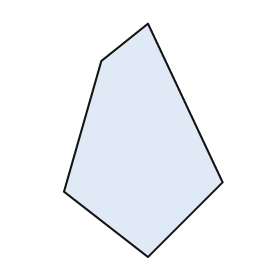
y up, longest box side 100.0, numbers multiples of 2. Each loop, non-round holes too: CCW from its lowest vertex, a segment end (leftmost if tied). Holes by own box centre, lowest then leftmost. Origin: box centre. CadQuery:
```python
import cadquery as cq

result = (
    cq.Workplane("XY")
    .moveTo(2.0, -50.0)
    .lineTo(34.0, -18.0)
    .lineTo(2.0, 50.0)
    .lineTo(-18.0, 34.0)
    .lineTo(-34.0, -22.0)
    .close()
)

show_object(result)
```